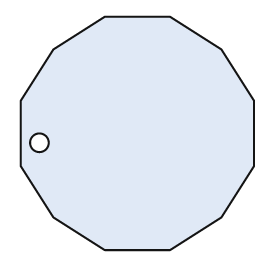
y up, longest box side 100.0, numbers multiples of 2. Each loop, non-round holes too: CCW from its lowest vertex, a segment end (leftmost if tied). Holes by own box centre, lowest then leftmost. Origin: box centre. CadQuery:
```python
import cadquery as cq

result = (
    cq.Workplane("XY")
    .moveTo(-14.0, -50.0)
    .lineTo(14.0, -50.0)
    .lineTo(36.0, -36.0)
    .lineTo(50.0, -14.0)
    .lineTo(50.0, 14.0)
    .lineTo(36.0, 36.0)
    .lineTo(14.0, 50.0)
    .lineTo(-14.0, 50.0)
    .lineTo(-36.0, 36.0)
    .lineTo(-50.0, 14.0)
    .lineTo(-50.0, -14.0)
    .lineTo(-36.0, -36.0)
    .close()
    .moveTo(-42.0, -4.0)
    .circle(4.0)
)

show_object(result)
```